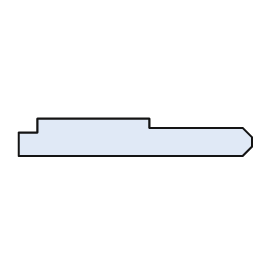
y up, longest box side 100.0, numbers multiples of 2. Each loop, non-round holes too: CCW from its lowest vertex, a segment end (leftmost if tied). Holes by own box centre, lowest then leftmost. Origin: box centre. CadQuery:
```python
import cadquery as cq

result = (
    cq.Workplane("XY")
    .moveTo(-50.0, -8.0)
    .lineTo(46.0, -8.0)
    .lineTo(50.0, -4.0)
    .lineTo(50.0, 0.0)
    .lineTo(46.0, 4.0)
    .lineTo(6.0, 4.0)
    .lineTo(6.0, 8.0)
    .lineTo(-42.0, 8.0)
    .lineTo(-42.0, 2.0)
    .lineTo(-50.0, 2.0)
    .close()
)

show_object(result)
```